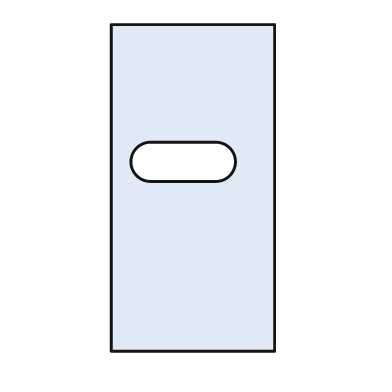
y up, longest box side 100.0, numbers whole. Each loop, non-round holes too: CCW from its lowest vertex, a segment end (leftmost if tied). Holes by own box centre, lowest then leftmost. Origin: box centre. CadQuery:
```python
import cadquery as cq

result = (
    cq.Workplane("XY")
    .moveTo(-25.0, -50.0)
    .lineTo(25.0, -50.0)
    .lineTo(25.0, 50.0)
    .lineTo(-25.0, 50.0)
    .close()
    .moveTo(-13.0, 2.0)
    .lineTo(7.0, 2.0)
    .threePointArc((13.0, 8.0), (7.0, 14.0))
    .lineTo(-13.0, 14.0)
    .threePointArc((-19.0, 8.0), (-13.0, 2.0))
    .close()
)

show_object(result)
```